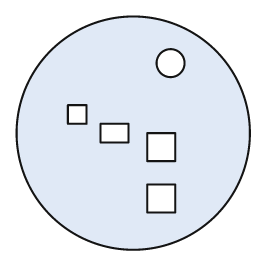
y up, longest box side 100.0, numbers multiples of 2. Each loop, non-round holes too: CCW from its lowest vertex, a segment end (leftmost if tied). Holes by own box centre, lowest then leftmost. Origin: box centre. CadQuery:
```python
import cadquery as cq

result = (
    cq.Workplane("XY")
    .moveTo(0.0, 0.0)
    .circle(50.0)
    .moveTo(6.0, -34.0)
    .lineTo(18.0, -34.0)
    .lineTo(18.0, -22.0)
    .lineTo(6.0, -22.0)
    .close()
    .moveTo(6.0, -12.0)
    .lineTo(18.0, -12.0)
    .lineTo(18.0, 0.0)
    .lineTo(6.0, 0.0)
    .close()
    .moveTo(-14.0, -4.0)
    .lineTo(-2.0, -4.0)
    .lineTo(-2.0, 4.0)
    .lineTo(-14.0, 4.0)
    .close()
    .moveTo(-28.0, 4.0)
    .lineTo(-20.0, 4.0)
    .lineTo(-20.0, 12.0)
    .lineTo(-28.0, 12.0)
    .close()
    .moveTo(16.0, 30.0)
    .circle(6.0)
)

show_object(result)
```